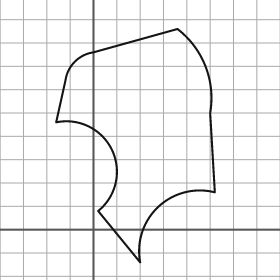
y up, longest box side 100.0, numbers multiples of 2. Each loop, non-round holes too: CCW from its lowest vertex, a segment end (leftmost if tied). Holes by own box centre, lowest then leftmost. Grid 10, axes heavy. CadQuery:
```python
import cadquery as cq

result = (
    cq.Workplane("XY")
    .moveTo(20.0, -14.0)
    .threePointArc((28.0, 10.0), (52.0, 16.0))
    .lineTo(50.0, 50.0)
    .threePointArc((48.0, 70.0), (36.0, 86.0))
    .lineTo(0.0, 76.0)
    .threePointArc((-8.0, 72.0), (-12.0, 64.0))
    .lineTo(-16.0, 46.0)
    .threePointArc((8.0, 34.0), (2.0, 8.0))
    .close()
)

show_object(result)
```